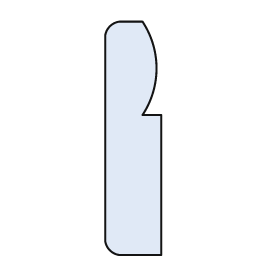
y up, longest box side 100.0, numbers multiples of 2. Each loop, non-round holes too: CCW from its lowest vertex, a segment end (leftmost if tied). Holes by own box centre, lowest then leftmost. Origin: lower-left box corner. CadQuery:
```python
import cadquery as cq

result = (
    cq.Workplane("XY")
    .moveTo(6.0, 0.0)
    .lineTo(24.0, 0.0)
    .lineTo(24.0, 60.0)
    .lineTo(16.0, 60.0)
    .threePointArc((22.0, 80.0), (16.0, 100.0))
    .lineTo(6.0, 100.0)
    .threePointArc((2.0, 98.0), (0.0, 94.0))
    .lineTo(0.0, 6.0)
    .threePointArc((2.0, 2.0), (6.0, 0.0))
    .close()
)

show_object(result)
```